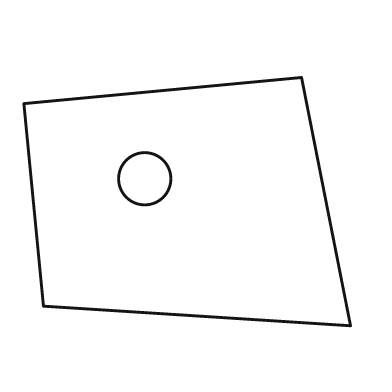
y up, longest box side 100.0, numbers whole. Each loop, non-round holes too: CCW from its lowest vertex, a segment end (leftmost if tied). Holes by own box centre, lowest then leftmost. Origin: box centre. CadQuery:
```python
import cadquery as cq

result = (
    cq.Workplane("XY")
    .moveTo(50.0, -38.0)
    .lineTo(35.0, 38.0)
    .lineTo(-50.0, 30.0)
    .lineTo(-44.0, -32.0)
    .close()
    .moveTo(-13.0, 7.0)
    .circle(8.0)
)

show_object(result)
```